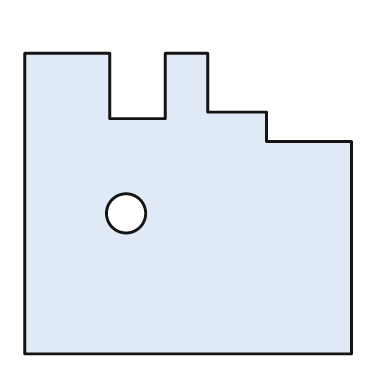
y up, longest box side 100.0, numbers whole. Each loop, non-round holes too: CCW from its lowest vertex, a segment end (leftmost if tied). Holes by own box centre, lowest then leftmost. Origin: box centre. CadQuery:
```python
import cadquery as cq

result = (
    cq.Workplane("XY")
    .moveTo(-50.0, -46.0)
    .lineTo(50.0, -46.0)
    .lineTo(50.0, 19.0)
    .lineTo(24.0, 19.0)
    .lineTo(24.0, 28.0)
    .lineTo(6.0, 28.0)
    .lineTo(6.0, 46.0)
    .lineTo(-7.0, 46.0)
    .lineTo(-7.0, 26.0)
    .lineTo(-24.0, 26.0)
    .lineTo(-24.0, 46.0)
    .lineTo(-50.0, 46.0)
    .close()
    .moveTo(-19.0, -3.0)
    .circle(6.0)
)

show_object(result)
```